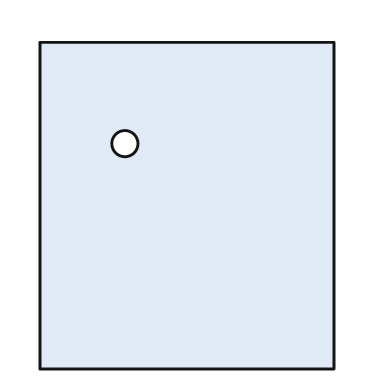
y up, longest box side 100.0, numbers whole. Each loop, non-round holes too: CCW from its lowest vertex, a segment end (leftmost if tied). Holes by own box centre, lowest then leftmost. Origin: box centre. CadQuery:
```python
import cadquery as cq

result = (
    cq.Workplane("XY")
    .moveTo(-45.0, -50.0)
    .lineTo(45.0, -50.0)
    .lineTo(45.0, 50.0)
    .lineTo(-45.0, 50.0)
    .close()
    .moveTo(-19.0, 19.0)
    .circle(4.0)
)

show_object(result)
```